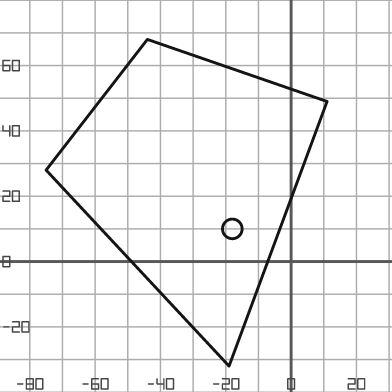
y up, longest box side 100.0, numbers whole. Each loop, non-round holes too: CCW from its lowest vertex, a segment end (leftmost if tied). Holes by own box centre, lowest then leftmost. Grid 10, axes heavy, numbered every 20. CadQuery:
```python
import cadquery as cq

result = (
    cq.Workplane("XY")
    .moveTo(-19.0, -32.0)
    .lineTo(11.0, 49.0)
    .lineTo(-44.0, 68.0)
    .lineTo(-75.0, 28.0)
    .close()
    .moveTo(-18.0, 10.0)
    .circle(3.0)
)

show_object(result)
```